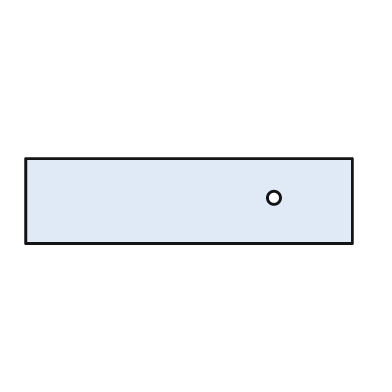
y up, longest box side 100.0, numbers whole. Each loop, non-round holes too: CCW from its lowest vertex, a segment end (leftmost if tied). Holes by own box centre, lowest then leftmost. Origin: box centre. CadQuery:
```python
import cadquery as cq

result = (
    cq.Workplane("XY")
    .moveTo(-50.0, -13.0)
    .lineTo(50.0, -13.0)
    .lineTo(50.0, 13.0)
    .lineTo(-50.0, 13.0)
    .close()
    .moveTo(26.0, 1.0)
    .circle(2.0)
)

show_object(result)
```